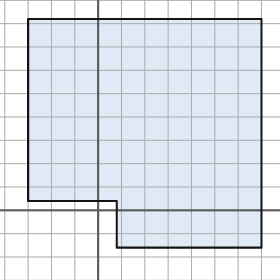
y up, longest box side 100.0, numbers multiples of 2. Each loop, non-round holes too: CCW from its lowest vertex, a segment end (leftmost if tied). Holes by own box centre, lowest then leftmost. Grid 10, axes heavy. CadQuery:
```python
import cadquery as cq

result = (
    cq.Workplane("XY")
    .moveTo(8.0, -16.0)
    .lineTo(70.0, -16.0)
    .lineTo(70.0, 82.0)
    .lineTo(-30.0, 82.0)
    .lineTo(-30.0, 4.0)
    .lineTo(8.0, 4.0)
    .close()
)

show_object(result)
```